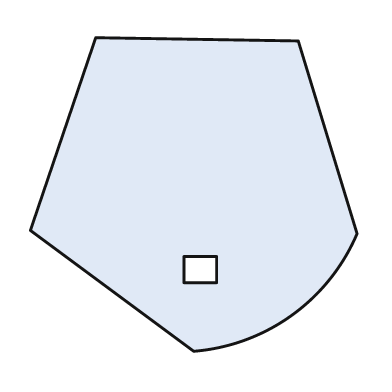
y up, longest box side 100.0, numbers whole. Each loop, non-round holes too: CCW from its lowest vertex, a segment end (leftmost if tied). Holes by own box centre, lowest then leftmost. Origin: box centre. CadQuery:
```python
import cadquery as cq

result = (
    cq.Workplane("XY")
    .moveTo(0.0, -48.0)
    .threePointArc((30.0, -37.0), (50.0, -12.0))
    .lineTo(32.0, 47.0)
    .lineTo(-30.0, 48.0)
    .lineTo(-50.0, -11.0)
    .close()
    .moveTo(-3.0, -27.0)
    .lineTo(7.0, -27.0)
    .lineTo(7.0, -19.0)
    .lineTo(-3.0, -19.0)
    .close()
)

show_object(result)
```